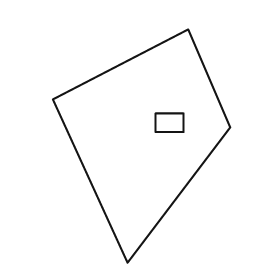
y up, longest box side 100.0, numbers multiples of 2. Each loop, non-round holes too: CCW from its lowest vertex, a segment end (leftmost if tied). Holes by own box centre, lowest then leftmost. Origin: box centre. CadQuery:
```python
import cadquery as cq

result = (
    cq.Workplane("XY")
    .moveTo(-6.0, -50.0)
    .lineTo(38.0, 8.0)
    .lineTo(20.0, 50.0)
    .lineTo(-38.0, 20.0)
    .close()
    .moveTo(6.0, 6.0)
    .lineTo(18.0, 6.0)
    .lineTo(18.0, 14.0)
    .lineTo(6.0, 14.0)
    .close()
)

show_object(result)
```